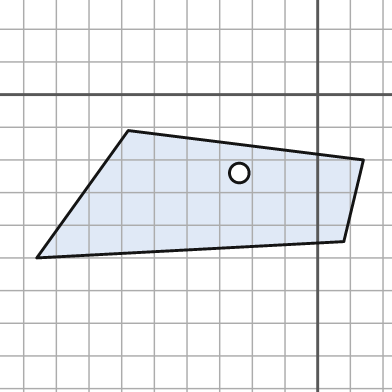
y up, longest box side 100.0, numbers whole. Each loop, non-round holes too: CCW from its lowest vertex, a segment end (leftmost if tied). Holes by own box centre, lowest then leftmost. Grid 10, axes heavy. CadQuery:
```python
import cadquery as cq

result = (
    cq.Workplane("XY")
    .moveTo(-86.0, -50.0)
    .lineTo(8.0, -45.0)
    .lineTo(14.0, -20.0)
    .lineTo(-58.0, -11.0)
    .close()
    .moveTo(-24.0, -24.0)
    .circle(3.0)
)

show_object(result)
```